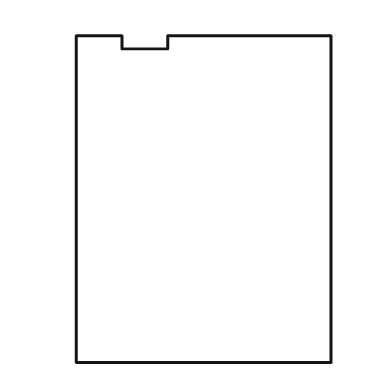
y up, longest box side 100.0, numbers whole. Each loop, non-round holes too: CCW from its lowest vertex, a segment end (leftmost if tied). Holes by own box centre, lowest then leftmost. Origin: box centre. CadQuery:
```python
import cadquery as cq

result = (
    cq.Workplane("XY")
    .moveTo(-39.0, -50.0)
    .lineTo(39.0, -50.0)
    .lineTo(39.0, 50.0)
    .lineTo(-11.0, 50.0)
    .lineTo(-11.0, 46.0)
    .lineTo(-25.0, 46.0)
    .lineTo(-25.0, 50.0)
    .lineTo(-39.0, 50.0)
    .close()
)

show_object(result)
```